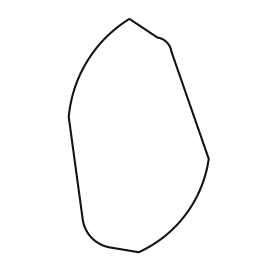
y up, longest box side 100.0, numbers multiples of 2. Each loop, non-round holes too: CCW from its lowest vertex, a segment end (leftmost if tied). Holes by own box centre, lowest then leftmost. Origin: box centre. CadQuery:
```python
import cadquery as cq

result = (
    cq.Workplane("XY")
    .moveTo(0.0, -50.0)
    .threePointArc((20.0, -34.0), (30.0, -10.0))
    .lineTo(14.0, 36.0)
    .threePointArc((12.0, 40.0), (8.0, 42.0))
    .lineTo(-4.0, 50.0)
    .threePointArc((-22.0, 32.0), (-30.0, 8.0))
    .lineTo(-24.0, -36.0)
    .threePointArc((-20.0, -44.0), (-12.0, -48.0))
    .close()
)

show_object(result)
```